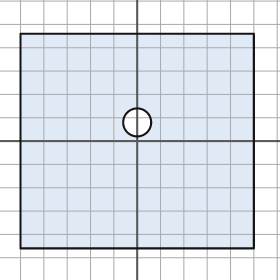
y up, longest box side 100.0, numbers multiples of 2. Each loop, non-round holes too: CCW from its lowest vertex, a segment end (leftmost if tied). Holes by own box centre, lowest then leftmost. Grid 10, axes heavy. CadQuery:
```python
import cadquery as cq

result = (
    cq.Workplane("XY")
    .moveTo(-50.0, -46.0)
    .lineTo(50.0, -46.0)
    .lineTo(50.0, 46.0)
    .lineTo(-50.0, 46.0)
    .close()
    .moveTo(0.0, 8.0)
    .circle(6.0)
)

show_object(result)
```